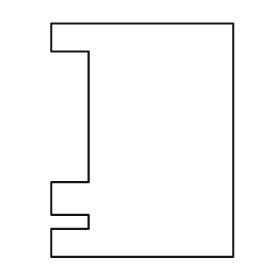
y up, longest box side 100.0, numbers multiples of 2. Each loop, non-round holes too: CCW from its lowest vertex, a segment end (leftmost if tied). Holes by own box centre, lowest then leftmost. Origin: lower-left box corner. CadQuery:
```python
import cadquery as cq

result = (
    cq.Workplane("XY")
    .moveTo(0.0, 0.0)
    .lineTo(78.0, 0.0)
    .lineTo(78.0, 100.0)
    .lineTo(0.0, 100.0)
    .lineTo(0.0, 88.0)
    .lineTo(16.0, 88.0)
    .lineTo(16.0, 32.0)
    .lineTo(0.0, 32.0)
    .lineTo(0.0, 18.0)
    .lineTo(16.0, 18.0)
    .lineTo(16.0, 12.0)
    .lineTo(0.0, 12.0)
    .close()
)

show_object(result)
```